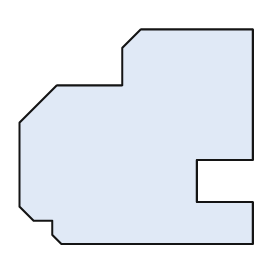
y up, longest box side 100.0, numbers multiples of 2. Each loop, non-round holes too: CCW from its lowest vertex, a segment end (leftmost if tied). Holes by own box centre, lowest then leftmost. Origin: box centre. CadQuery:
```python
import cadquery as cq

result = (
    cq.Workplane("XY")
    .moveTo(-32.0, -46.0)
    .lineTo(50.0, -46.0)
    .lineTo(50.0, -28.0)
    .lineTo(26.0, -28.0)
    .lineTo(26.0, -10.0)
    .lineTo(50.0, -10.0)
    .lineTo(50.0, 46.0)
    .lineTo(2.0, 46.0)
    .lineTo(-6.0, 38.0)
    .lineTo(-6.0, 22.0)
    .lineTo(-34.0, 22.0)
    .lineTo(-50.0, 6.0)
    .lineTo(-50.0, -30.0)
    .lineTo(-44.0, -36.0)
    .lineTo(-36.0, -36.0)
    .lineTo(-36.0, -42.0)
    .close()
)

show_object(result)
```